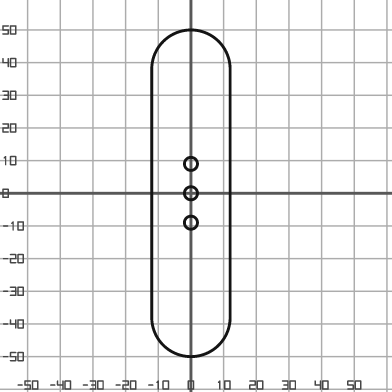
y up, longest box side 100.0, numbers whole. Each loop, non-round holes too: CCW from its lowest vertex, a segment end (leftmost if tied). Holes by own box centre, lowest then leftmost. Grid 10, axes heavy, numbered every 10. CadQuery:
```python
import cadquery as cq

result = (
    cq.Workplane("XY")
    .moveTo(-12.0, -38.0)
    .threePointArc((0.0, -50.0), (12.0, -38.0))
    .lineTo(12.0, 38.0)
    .threePointArc((0.0, 50.0), (-12.0, 38.0))
    .close()
    .moveTo(0.0, -9.0)
    .circle(2.0)
    .moveTo(0.0, 0.0)
    .circle(2.0)
    .moveTo(0.0, 9.0)
    .circle(2.0)
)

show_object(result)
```